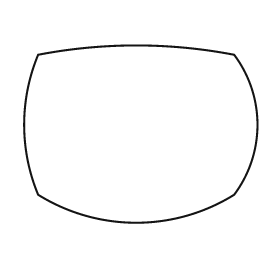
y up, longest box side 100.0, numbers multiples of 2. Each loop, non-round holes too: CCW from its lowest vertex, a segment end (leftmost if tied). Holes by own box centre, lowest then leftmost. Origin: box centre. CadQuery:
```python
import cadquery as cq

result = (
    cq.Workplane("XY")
    .moveTo(-44.0, -26.0)
    .threePointArc((-2.0, -38.0), (40.0, -26.0))
    .threePointArc((50.0, 4.0), (40.0, 34.0))
    .threePointArc((-2.0, 38.0), (-44.0, 34.0))
    .threePointArc((-50.0, 4.0), (-44.0, -26.0))
    .close()
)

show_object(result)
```